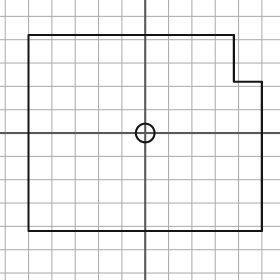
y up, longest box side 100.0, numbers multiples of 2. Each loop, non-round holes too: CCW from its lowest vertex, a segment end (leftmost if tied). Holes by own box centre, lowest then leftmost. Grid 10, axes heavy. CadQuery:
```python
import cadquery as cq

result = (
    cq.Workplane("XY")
    .moveTo(-50.0, -42.0)
    .lineTo(50.0, -42.0)
    .lineTo(50.0, 22.0)
    .lineTo(38.0, 22.0)
    .lineTo(38.0, 42.0)
    .lineTo(-50.0, 42.0)
    .close()
    .moveTo(0.0, 0.0)
    .circle(4.0)
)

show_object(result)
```